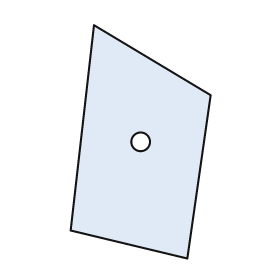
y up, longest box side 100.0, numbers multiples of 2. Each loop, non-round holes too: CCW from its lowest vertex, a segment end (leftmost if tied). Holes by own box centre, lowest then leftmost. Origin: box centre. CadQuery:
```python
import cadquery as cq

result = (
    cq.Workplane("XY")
    .moveTo(20.0, -50.0)
    .lineTo(30.0, 20.0)
    .lineTo(-20.0, 50.0)
    .lineTo(-30.0, -38.0)
    .close()
    .moveTo(0.0, 0.0)
    .circle(4.0)
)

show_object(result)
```